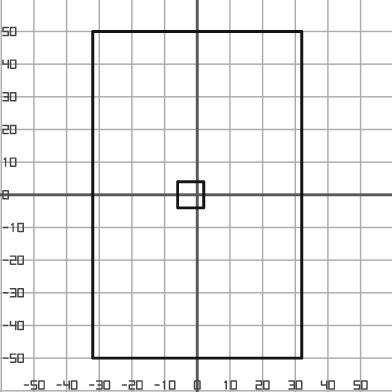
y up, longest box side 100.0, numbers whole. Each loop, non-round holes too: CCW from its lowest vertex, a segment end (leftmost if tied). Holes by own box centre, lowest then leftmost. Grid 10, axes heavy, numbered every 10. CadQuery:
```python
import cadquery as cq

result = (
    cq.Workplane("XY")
    .moveTo(-32.0, -50.0)
    .lineTo(32.0, -50.0)
    .lineTo(32.0, 50.0)
    .lineTo(-32.0, 50.0)
    .close()
    .moveTo(-6.0, -4.0)
    .lineTo(2.0, -4.0)
    .lineTo(2.0, 4.0)
    .lineTo(-6.0, 4.0)
    .close()
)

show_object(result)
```